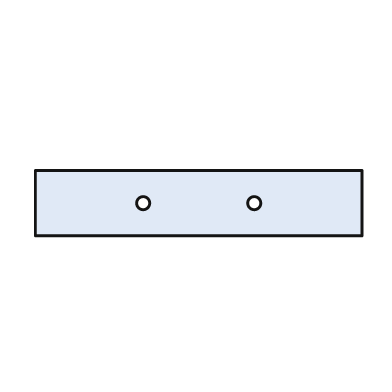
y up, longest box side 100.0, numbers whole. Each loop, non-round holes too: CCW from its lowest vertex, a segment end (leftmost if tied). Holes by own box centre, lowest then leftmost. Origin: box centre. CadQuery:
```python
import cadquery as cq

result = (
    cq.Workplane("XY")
    .moveTo(-50.0, -10.0)
    .lineTo(50.0, -10.0)
    .lineTo(50.0, 10.0)
    .lineTo(-50.0, 10.0)
    .close()
    .moveTo(-17.0, 0.0)
    .circle(2.0)
    .moveTo(17.0, 0.0)
    .circle(2.0)
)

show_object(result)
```